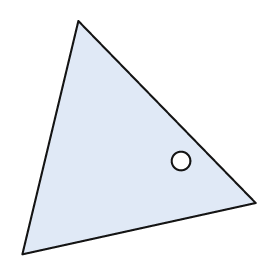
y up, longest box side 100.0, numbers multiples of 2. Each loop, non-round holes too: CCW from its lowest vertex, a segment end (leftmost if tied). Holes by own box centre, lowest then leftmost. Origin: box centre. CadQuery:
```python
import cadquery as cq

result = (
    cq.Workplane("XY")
    .moveTo(-50.0, -50.0)
    .lineTo(50.0, -28.0)
    .lineTo(-26.0, 50.0)
    .close()
    .moveTo(18.0, -10.0)
    .circle(4.0)
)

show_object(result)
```